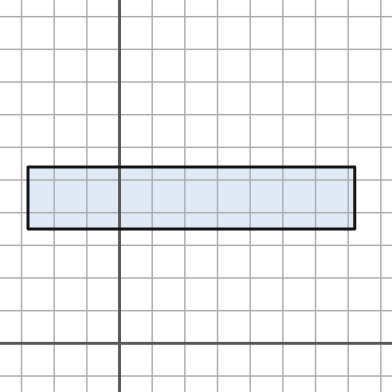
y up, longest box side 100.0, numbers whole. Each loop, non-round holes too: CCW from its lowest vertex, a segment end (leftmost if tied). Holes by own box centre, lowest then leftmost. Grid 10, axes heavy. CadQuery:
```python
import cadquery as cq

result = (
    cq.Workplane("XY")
    .moveTo(-28.0, 35.0)
    .lineTo(72.0, 35.0)
    .lineTo(72.0, 54.0)
    .lineTo(-28.0, 54.0)
    .close()
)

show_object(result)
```